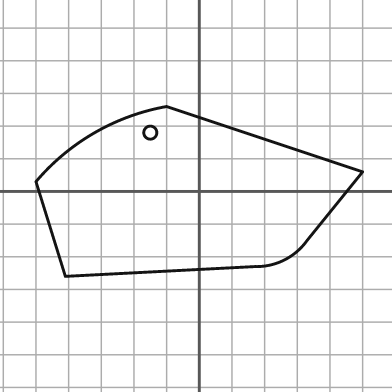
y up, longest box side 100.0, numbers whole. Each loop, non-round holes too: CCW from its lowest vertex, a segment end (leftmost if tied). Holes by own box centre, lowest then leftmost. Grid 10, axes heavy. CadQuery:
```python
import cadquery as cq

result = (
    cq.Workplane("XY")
    .moveTo(-41.0, -26.0)
    .lineTo(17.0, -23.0)
    .threePointArc((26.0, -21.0), (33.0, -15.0))
    .lineTo(50.0, 6.0)
    .lineTo(-10.0, 26.0)
    .threePointArc((-32.0, 18.0), (-50.0, 3.0))
    .close()
    .moveTo(-15.0, 18.0)
    .circle(2.0)
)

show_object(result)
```